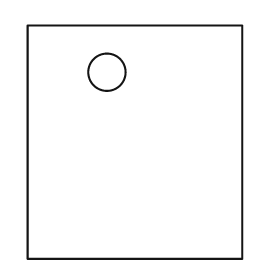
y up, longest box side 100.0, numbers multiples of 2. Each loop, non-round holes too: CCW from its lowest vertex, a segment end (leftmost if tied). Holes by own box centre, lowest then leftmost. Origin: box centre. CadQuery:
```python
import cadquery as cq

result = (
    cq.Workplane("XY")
    .moveTo(-46.0, -50.0)
    .lineTo(46.0, -50.0)
    .lineTo(46.0, 50.0)
    .lineTo(-46.0, 50.0)
    .close()
    .moveTo(-12.0, 30.0)
    .circle(8.0)
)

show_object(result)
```